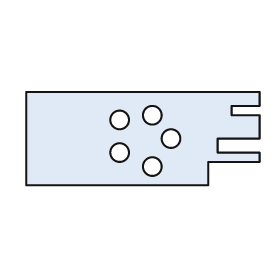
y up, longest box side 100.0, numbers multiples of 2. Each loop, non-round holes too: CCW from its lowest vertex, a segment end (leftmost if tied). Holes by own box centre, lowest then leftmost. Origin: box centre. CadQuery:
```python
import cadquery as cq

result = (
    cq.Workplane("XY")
    .moveTo(-50.0, -20.0)
    .lineTo(28.0, -20.0)
    .lineTo(28.0, -10.0)
    .lineTo(50.0, -10.0)
    .lineTo(50.0, -6.0)
    .lineTo(32.0, -6.0)
    .lineTo(32.0, 0.0)
    .lineTo(50.0, 0.0)
    .lineTo(50.0, 10.0)
    .lineTo(38.0, 10.0)
    .lineTo(38.0, 14.0)
    .lineTo(50.0, 14.0)
    .lineTo(50.0, 20.0)
    .lineTo(-50.0, 20.0)
    .close()
    .moveTo(4.0, -12.0)
    .circle(4.0)
    .moveTo(-10.0, -6.0)
    .circle(4.0)
    .moveTo(12.0, 0.0)
    .circle(4.0)
    .moveTo(-10.0, 8.0)
    .circle(4.0)
    .moveTo(4.0, 10.0)
    .circle(4.0)
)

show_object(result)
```